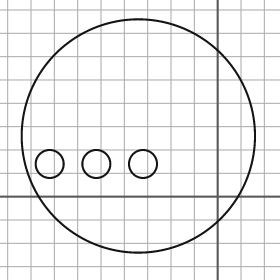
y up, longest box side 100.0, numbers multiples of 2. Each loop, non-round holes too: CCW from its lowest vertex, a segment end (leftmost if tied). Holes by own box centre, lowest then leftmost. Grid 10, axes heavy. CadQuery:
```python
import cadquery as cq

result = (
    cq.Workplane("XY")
    .moveTo(-34.0, 26.0)
    .circle(50.0)
    .moveTo(-72.0, 14.0)
    .circle(6.0)
    .moveTo(-52.0, 14.0)
    .circle(6.0)
    .moveTo(-32.0, 14.0)
    .circle(6.0)
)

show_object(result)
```